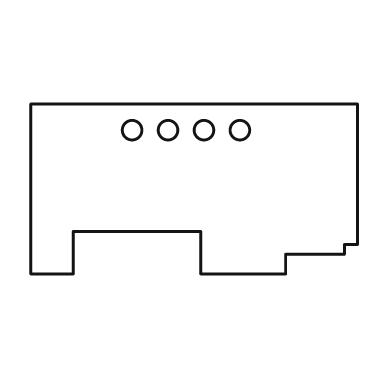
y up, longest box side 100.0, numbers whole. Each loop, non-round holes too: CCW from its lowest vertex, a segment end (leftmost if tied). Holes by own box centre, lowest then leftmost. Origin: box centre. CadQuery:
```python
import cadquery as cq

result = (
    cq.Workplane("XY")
    .moveTo(-50.0, -26.0)
    .lineTo(-37.0, -26.0)
    .lineTo(-37.0, -13.0)
    .lineTo(2.0, -13.0)
    .lineTo(2.0, -26.0)
    .lineTo(28.0, -26.0)
    .lineTo(28.0, -20.0)
    .lineTo(46.0, -20.0)
    .lineTo(46.0, -17.0)
    .lineTo(50.0, -17.0)
    .lineTo(50.0, 26.0)
    .lineTo(-50.0, 26.0)
    .close()
    .moveTo(-19.0, 18.0)
    .circle(3.0)
    .moveTo(-8.0, 18.0)
    .circle(3.0)
    .moveTo(3.0, 18.0)
    .circle(3.0)
    .moveTo(14.0, 18.0)
    .circle(3.0)
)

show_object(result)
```